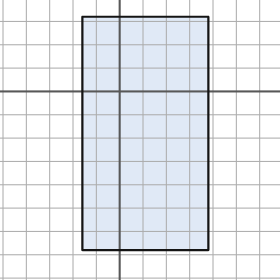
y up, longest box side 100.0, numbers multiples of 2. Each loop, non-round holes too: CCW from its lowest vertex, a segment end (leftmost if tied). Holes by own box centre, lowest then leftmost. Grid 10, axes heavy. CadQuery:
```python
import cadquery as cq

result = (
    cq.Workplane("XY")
    .moveTo(-16.0, -68.0)
    .lineTo(38.0, -68.0)
    .lineTo(38.0, 32.0)
    .lineTo(-16.0, 32.0)
    .close()
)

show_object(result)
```